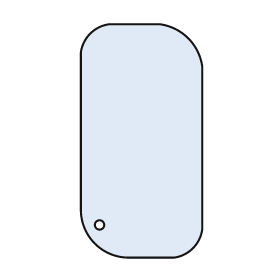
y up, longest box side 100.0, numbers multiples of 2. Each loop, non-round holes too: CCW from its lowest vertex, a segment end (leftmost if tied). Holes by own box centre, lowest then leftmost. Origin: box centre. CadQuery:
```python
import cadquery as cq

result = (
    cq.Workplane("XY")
    .moveTo(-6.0, -50.0)
    .lineTo(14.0, -50.0)
    .threePointArc((22.0, -46.0), (26.0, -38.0))
    .lineTo(26.0, 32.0)
    .threePointArc((20.0, 44.0), (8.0, 50.0))
    .lineTo(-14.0, 50.0)
    .threePointArc((-22.0, 46.0), (-26.0, 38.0))
    .lineTo(-26.0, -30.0)
    .threePointArc((-20.0, -44.0), (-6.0, -50.0))
    .close()
    .moveTo(-18.0, -36.0)
    .circle(2.0)
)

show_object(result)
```